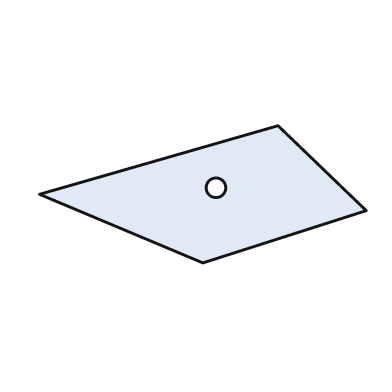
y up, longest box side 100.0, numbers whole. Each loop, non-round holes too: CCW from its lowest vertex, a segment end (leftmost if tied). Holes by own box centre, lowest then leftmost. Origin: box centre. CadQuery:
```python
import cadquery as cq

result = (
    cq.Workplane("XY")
    .moveTo(0.0, -21.0)
    .lineTo(50.0, -5.0)
    .lineTo(23.0, 21.0)
    .lineTo(-50.0, 0.0)
    .close()
    .moveTo(4.0, 2.0)
    .circle(3.0)
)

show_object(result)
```